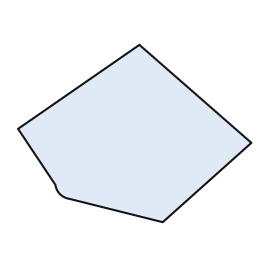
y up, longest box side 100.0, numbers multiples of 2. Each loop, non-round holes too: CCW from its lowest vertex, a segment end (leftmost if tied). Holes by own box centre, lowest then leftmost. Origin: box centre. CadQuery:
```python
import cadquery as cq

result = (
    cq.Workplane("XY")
    .moveTo(12.0, -38.0)
    .lineTo(50.0, -4.0)
    .lineTo(2.0, 38.0)
    .lineTo(-50.0, 2.0)
    .lineTo(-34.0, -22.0)
    .threePointArc((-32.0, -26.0), (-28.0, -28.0))
    .close()
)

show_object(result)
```